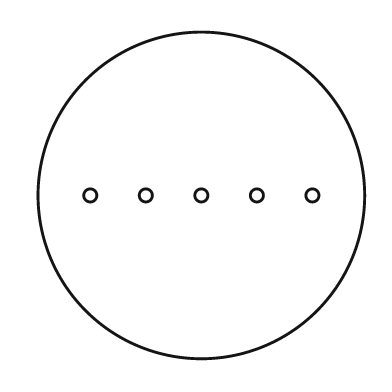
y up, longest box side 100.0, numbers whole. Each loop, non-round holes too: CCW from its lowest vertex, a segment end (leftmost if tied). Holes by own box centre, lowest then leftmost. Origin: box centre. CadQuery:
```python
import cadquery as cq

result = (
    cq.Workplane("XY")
    .moveTo(0.0, 0.0)
    .circle(50.0)
    .moveTo(-34.0, 0.0)
    .circle(2.0)
    .moveTo(-17.0, 0.0)
    .circle(2.0)
    .moveTo(0.0, 0.0)
    .circle(2.0)
    .moveTo(17.0, 0.0)
    .circle(2.0)
    .moveTo(34.0, 0.0)
    .circle(2.0)
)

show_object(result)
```